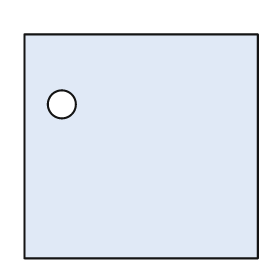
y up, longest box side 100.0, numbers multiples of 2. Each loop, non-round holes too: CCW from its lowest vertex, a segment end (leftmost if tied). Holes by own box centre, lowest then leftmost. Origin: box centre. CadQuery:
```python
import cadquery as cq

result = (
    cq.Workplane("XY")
    .moveTo(-50.0, -48.0)
    .lineTo(50.0, -48.0)
    .lineTo(50.0, 48.0)
    .lineTo(-50.0, 48.0)
    .close()
    .moveTo(-34.0, 18.0)
    .circle(6.0)
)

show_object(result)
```